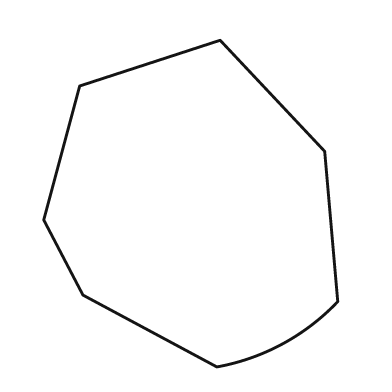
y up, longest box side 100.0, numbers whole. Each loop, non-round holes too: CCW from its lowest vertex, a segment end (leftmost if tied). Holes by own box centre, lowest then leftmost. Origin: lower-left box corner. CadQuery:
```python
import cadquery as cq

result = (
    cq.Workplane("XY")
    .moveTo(53.0, 0.0)
    .threePointArc((73.0, 7.0), (90.0, 20.0))
    .lineTo(86.0, 66.0)
    .lineTo(54.0, 100.0)
    .lineTo(11.0, 86.0)
    .lineTo(0.0, 45.0)
    .lineTo(12.0, 22.0)
    .close()
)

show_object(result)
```